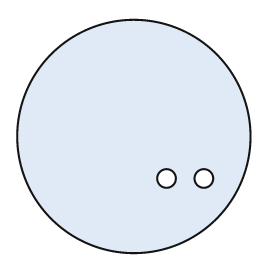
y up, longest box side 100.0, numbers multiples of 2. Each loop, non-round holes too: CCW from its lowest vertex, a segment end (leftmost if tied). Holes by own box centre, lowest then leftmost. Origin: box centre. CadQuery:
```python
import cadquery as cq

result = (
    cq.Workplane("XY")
    .moveTo(0.0, 0.0)
    .circle(50.0)
    .moveTo(14.0, -18.0)
    .circle(4.0)
    .moveTo(30.0, -18.0)
    .circle(4.0)
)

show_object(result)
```